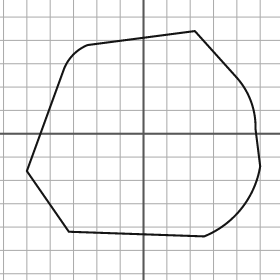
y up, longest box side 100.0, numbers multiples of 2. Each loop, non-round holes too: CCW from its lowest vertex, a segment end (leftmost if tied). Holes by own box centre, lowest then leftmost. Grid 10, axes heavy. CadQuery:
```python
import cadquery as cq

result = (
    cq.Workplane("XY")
    .moveTo(26.0, -44.0)
    .threePointArc((42.0, -32.0), (50.0, -14.0))
    .lineTo(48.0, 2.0)
    .threePointArc((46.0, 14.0), (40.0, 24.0))
    .lineTo(22.0, 44.0)
    .lineTo(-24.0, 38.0)
    .threePointArc((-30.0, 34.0), (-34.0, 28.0))
    .lineTo(-50.0, -16.0)
    .lineTo(-32.0, -42.0)
    .close()
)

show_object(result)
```